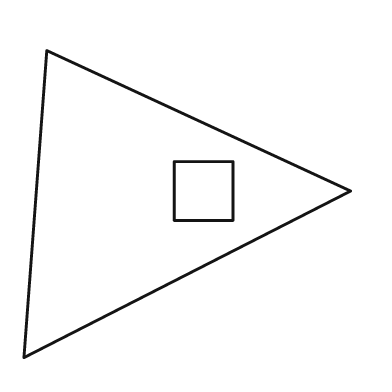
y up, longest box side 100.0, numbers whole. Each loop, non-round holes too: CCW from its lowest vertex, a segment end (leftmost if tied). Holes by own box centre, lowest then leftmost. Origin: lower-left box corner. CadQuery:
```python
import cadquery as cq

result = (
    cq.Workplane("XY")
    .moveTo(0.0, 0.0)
    .lineTo(100.0, 51.0)
    .lineTo(7.0, 94.0)
    .close()
    .moveTo(46.0, 42.0)
    .lineTo(64.0, 42.0)
    .lineTo(64.0, 60.0)
    .lineTo(46.0, 60.0)
    .close()
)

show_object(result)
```